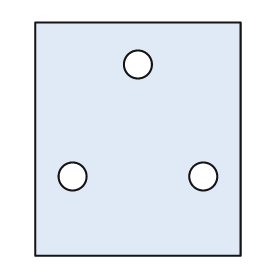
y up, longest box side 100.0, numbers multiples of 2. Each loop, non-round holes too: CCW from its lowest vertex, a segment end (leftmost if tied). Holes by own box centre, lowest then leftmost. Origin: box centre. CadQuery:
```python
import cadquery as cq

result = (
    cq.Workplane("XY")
    .moveTo(-44.0, -50.0)
    .lineTo(44.0, -50.0)
    .lineTo(44.0, 50.0)
    .lineTo(-44.0, 50.0)
    .close()
    .moveTo(-28.0, -16.0)
    .circle(6.0)
    .moveTo(28.0, -16.0)
    .circle(6.0)
    .moveTo(0.0, 32.0)
    .circle(6.0)
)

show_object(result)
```